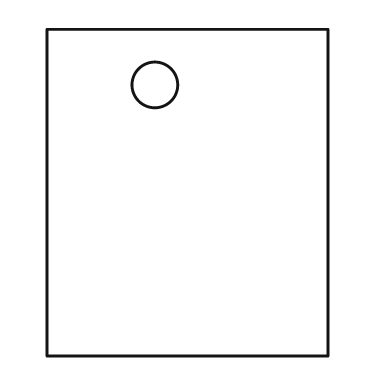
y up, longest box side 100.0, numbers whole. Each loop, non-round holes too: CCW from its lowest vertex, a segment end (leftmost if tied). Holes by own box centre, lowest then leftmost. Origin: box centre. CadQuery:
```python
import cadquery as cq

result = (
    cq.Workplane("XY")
    .moveTo(-43.0, -50.0)
    .lineTo(43.0, -50.0)
    .lineTo(43.0, 50.0)
    .lineTo(-43.0, 50.0)
    .close()
    .moveTo(-10.0, 33.0)
    .circle(7.0)
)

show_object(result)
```